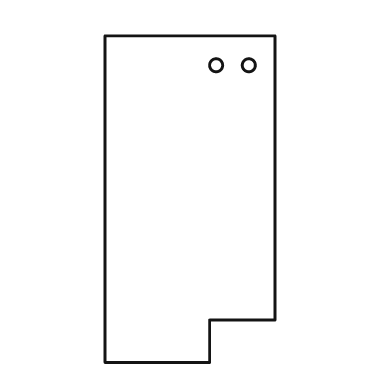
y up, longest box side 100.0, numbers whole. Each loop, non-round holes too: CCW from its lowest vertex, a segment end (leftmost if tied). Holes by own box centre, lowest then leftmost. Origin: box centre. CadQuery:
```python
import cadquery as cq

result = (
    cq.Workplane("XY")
    .moveTo(-26.0, -50.0)
    .lineTo(6.0, -50.0)
    .lineTo(6.0, -37.0)
    .lineTo(26.0, -37.0)
    .lineTo(26.0, 50.0)
    .lineTo(-26.0, 50.0)
    .close()
    .moveTo(8.0, 41.0)
    .circle(2.0)
    .moveTo(18.0, 41.0)
    .circle(2.0)
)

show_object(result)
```